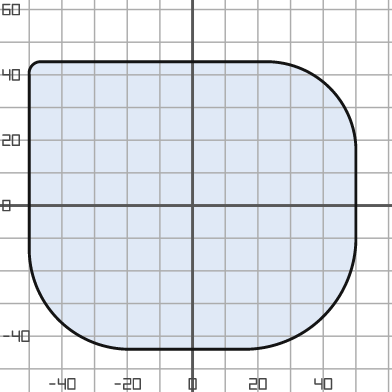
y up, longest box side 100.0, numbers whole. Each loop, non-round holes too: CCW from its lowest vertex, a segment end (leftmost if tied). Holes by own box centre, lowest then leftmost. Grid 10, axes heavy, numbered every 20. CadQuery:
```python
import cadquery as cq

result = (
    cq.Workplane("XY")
    .moveTo(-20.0, -44.0)
    .lineTo(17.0, -44.0)
    .threePointArc((40.0, -34.0), (50.0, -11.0))
    .lineTo(50.0, 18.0)
    .threePointArc((42.0, 36.0), (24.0, 44.0))
    .lineTo(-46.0, 44.0)
    .threePointArc((-49.0, 43.0), (-50.0, 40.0))
    .lineTo(-50.0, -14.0)
    .threePointArc((-41.0, -35.0), (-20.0, -44.0))
    .close()
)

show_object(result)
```